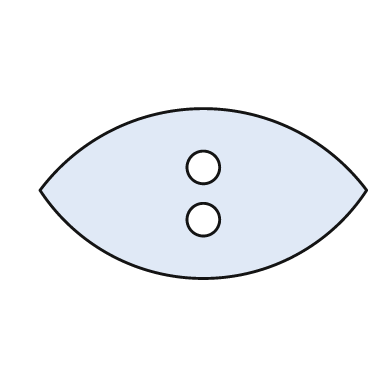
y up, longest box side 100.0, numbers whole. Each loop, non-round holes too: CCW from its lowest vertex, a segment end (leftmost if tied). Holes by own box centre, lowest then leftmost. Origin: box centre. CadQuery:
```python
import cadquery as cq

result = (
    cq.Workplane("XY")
    .moveTo(-50.0, 1.0)
    .threePointArc((0.0, -26.0), (50.0, 1.0))
    .threePointArc((0.0, 26.0), (-50.0, 1.0))
    .close()
    .moveTo(0.0, -8.0)
    .circle(5.0)
    .moveTo(0.0, 8.0)
    .circle(5.0)
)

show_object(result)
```